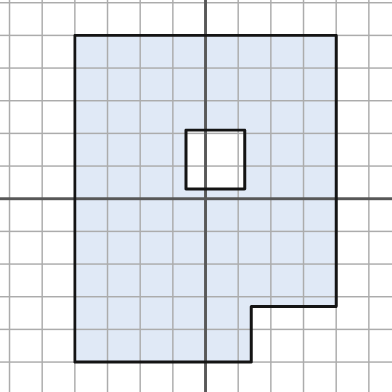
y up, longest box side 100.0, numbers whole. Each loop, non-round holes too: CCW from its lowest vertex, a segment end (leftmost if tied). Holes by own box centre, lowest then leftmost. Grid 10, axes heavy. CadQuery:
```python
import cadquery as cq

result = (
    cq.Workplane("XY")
    .moveTo(-40.0, -50.0)
    .lineTo(14.0, -50.0)
    .lineTo(14.0, -33.0)
    .lineTo(40.0, -33.0)
    .lineTo(40.0, 50.0)
    .lineTo(-40.0, 50.0)
    .close()
    .moveTo(-6.0, 3.0)
    .lineTo(12.0, 3.0)
    .lineTo(12.0, 21.0)
    .lineTo(-6.0, 21.0)
    .close()
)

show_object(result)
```